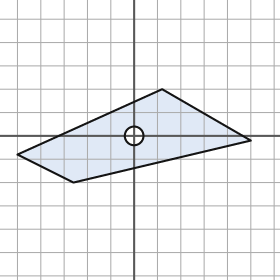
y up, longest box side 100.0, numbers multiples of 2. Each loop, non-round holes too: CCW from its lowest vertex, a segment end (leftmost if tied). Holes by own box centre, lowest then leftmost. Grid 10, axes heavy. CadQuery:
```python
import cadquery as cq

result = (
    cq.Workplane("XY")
    .moveTo(-26.0, -20.0)
    .lineTo(50.0, -2.0)
    .lineTo(12.0, 20.0)
    .lineTo(-50.0, -8.0)
    .close()
    .moveTo(0.0, 0.0)
    .circle(4.0)
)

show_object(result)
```